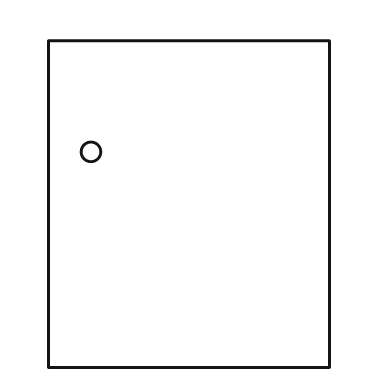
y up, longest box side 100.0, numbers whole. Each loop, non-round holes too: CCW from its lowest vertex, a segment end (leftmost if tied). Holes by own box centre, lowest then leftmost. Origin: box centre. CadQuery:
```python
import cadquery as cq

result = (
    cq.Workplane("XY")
    .moveTo(-43.0, -50.0)
    .lineTo(43.0, -50.0)
    .lineTo(43.0, 50.0)
    .lineTo(-43.0, 50.0)
    .close()
    .moveTo(-30.0, 16.0)
    .circle(3.0)
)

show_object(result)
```